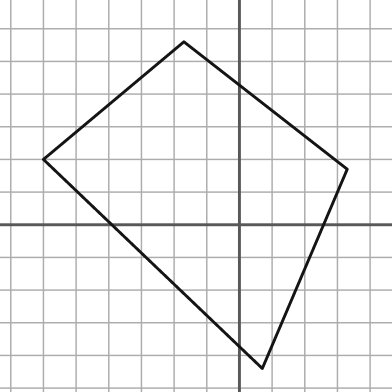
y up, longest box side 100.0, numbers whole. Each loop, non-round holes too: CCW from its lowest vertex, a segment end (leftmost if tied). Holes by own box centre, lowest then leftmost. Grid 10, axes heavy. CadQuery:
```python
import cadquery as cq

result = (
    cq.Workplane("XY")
    .moveTo(7.0, -44.0)
    .lineTo(33.0, 17.0)
    .lineTo(-17.0, 56.0)
    .lineTo(-60.0, 20.0)
    .close()
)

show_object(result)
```